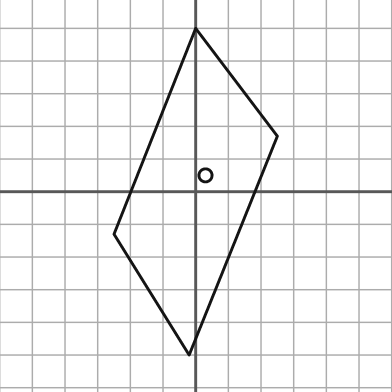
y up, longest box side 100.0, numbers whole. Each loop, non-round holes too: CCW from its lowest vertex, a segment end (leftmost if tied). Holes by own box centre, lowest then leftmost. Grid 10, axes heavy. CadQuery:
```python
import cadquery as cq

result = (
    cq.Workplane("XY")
    .moveTo(-2.0, -50.0)
    .lineTo(25.0, 17.0)
    .lineTo(0.0, 50.0)
    .lineTo(-25.0, -13.0)
    .close()
    .moveTo(3.0, 5.0)
    .circle(2.0)
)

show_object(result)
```